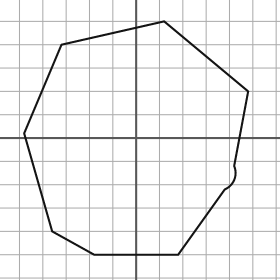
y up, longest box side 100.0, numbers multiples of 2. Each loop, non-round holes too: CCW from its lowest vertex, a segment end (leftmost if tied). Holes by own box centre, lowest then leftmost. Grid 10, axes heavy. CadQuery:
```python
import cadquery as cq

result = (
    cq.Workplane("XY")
    .moveTo(-18.0, -50.0)
    .lineTo(18.0, -50.0)
    .lineTo(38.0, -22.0)
    .threePointArc((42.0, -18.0), (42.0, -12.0))
    .lineTo(48.0, 20.0)
    .lineTo(12.0, 50.0)
    .lineTo(-32.0, 40.0)
    .lineTo(-48.0, 2.0)
    .lineTo(-36.0, -40.0)
    .close()
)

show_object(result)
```